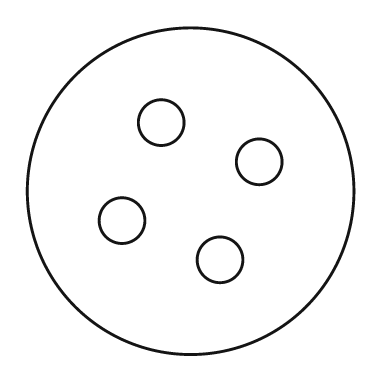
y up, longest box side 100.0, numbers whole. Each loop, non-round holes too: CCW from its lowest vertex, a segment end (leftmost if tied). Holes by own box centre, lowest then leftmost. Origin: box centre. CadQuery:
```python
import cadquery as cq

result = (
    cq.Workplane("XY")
    .moveTo(0.0, 0.0)
    .circle(50.0)
    .moveTo(9.0, -21.0)
    .circle(7.0)
    .moveTo(-21.0, -9.0)
    .circle(7.0)
    .moveTo(21.0, 9.0)
    .circle(7.0)
    .moveTo(-9.0, 21.0)
    .circle(7.0)
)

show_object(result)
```